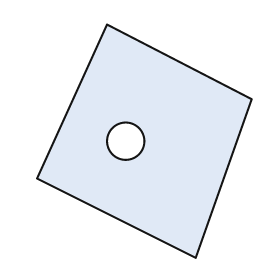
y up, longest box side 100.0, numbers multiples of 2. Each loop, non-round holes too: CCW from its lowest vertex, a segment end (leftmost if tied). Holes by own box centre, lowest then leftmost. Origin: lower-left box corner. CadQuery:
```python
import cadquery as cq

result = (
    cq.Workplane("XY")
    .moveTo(68.0, 0.0)
    .lineTo(92.0, 68.0)
    .lineTo(30.0, 100.0)
    .lineTo(0.0, 34.0)
    .close()
    .moveTo(38.0, 50.0)
    .circle(8.0)
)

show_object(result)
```